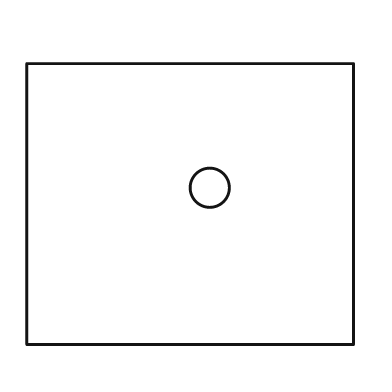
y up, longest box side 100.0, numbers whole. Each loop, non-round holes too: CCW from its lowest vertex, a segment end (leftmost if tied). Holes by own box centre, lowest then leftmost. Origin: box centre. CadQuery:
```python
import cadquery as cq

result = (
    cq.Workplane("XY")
    .moveTo(-50.0, -43.0)
    .lineTo(50.0, -43.0)
    .lineTo(50.0, 43.0)
    .lineTo(-50.0, 43.0)
    .close()
    .moveTo(6.0, 5.0)
    .circle(6.0)
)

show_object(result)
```